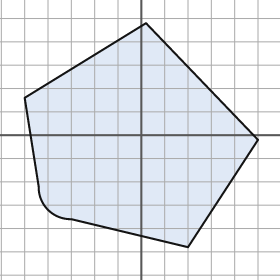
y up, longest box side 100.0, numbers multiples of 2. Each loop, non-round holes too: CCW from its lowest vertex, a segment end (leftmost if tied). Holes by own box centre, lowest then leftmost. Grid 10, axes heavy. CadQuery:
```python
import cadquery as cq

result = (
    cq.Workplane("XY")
    .moveTo(20.0, -48.0)
    .lineTo(50.0, -2.0)
    .lineTo(2.0, 48.0)
    .lineTo(-50.0, 16.0)
    .lineTo(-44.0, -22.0)
    .threePointArc((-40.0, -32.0), (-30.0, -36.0))
    .close()
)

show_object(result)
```